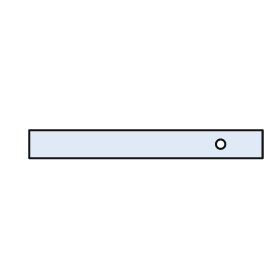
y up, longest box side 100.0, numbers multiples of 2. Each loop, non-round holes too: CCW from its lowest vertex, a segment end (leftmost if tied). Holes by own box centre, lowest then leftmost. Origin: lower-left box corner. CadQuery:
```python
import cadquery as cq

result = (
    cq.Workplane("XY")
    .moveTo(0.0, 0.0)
    .lineTo(100.0, 0.0)
    .lineTo(100.0, 12.0)
    .lineTo(0.0, 12.0)
    .close()
    .moveTo(82.0, 6.0)
    .circle(2.0)
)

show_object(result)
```